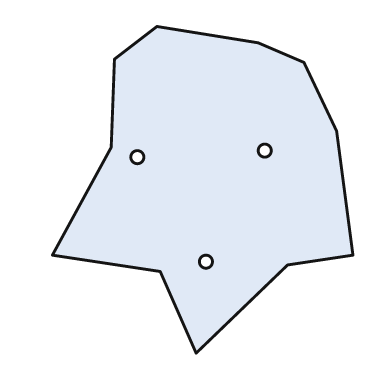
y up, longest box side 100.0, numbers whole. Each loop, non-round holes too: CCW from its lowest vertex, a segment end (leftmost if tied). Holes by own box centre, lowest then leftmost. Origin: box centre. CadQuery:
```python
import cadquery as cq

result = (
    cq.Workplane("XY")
    .moveTo(-2.0, -50.0)
    .lineTo(26.0, -23.0)
    .lineTo(46.0, -20.0)
    .lineTo(41.0, 18.0)
    .lineTo(31.0, 39.0)
    .lineTo(17.0, 45.0)
    .lineTo(-14.0, 50.0)
    .lineTo(-27.0, 40.0)
    .lineTo(-28.0, 13.0)
    .lineTo(-46.0, -20.0)
    .lineTo(-13.0, -25.0)
    .close()
    .moveTo(1.0, -22.0)
    .circle(2.0)
    .moveTo(-20.0, 10.0)
    .circle(2.0)
    .moveTo(19.0, 12.0)
    .circle(2.0)
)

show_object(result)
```